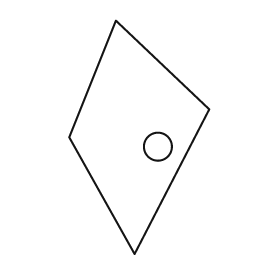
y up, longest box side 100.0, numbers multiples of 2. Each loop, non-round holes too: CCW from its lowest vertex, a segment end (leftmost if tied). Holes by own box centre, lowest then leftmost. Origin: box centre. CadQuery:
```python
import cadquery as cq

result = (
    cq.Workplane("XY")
    .moveTo(-2.0, -50.0)
    .lineTo(30.0, 12.0)
    .lineTo(-10.0, 50.0)
    .lineTo(-30.0, 0.0)
    .close()
    .moveTo(8.0, -4.0)
    .circle(6.0)
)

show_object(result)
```